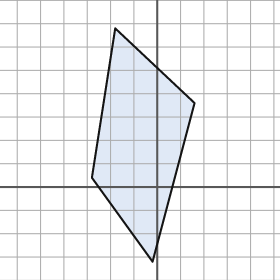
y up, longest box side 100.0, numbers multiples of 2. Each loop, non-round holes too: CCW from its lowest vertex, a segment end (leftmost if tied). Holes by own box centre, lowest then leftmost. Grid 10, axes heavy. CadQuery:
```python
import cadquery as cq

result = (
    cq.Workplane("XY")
    .moveTo(-2.0, -32.0)
    .lineTo(16.0, 36.0)
    .lineTo(-18.0, 68.0)
    .lineTo(-28.0, 4.0)
    .close()
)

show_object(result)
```